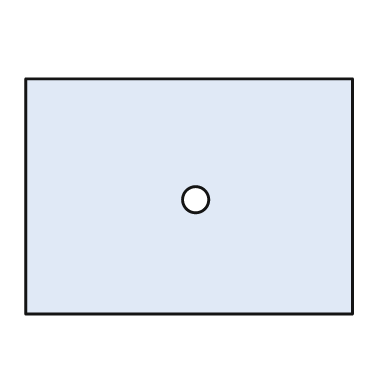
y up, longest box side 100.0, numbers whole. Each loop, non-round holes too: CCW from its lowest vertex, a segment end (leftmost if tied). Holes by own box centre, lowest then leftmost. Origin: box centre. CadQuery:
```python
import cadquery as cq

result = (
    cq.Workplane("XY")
    .moveTo(-50.0, -36.0)
    .lineTo(50.0, -36.0)
    .lineTo(50.0, 36.0)
    .lineTo(-50.0, 36.0)
    .close()
    .moveTo(2.0, -1.0)
    .circle(4.0)
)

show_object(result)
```